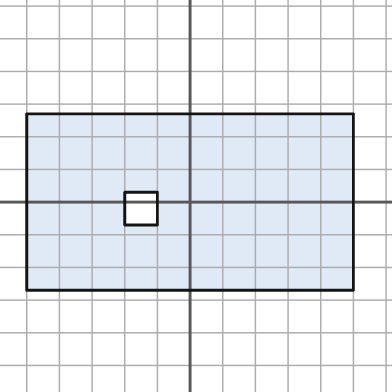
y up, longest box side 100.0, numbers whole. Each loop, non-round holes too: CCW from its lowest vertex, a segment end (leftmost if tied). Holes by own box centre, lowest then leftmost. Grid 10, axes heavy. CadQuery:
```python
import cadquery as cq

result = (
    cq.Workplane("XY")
    .moveTo(-50.0, -27.0)
    .lineTo(50.0, -27.0)
    .lineTo(50.0, 27.0)
    .lineTo(-50.0, 27.0)
    .close()
    .moveTo(-20.0, -7.0)
    .lineTo(-10.0, -7.0)
    .lineTo(-10.0, 3.0)
    .lineTo(-20.0, 3.0)
    .close()
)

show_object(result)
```